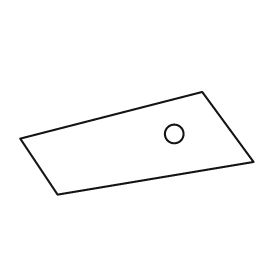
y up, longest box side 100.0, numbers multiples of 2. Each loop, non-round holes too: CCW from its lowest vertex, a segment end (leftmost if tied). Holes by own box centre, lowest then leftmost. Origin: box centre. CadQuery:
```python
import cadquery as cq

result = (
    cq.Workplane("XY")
    .moveTo(-34.0, -22.0)
    .lineTo(50.0, -8.0)
    .lineTo(28.0, 22.0)
    .lineTo(-50.0, 2.0)
    .close()
    .moveTo(16.0, 4.0)
    .circle(4.0)
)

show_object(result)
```